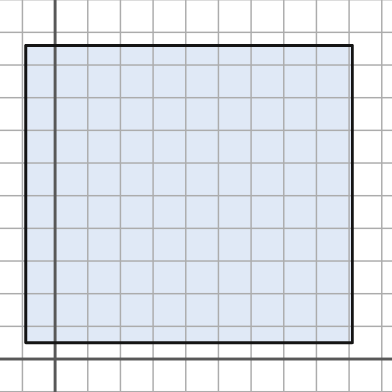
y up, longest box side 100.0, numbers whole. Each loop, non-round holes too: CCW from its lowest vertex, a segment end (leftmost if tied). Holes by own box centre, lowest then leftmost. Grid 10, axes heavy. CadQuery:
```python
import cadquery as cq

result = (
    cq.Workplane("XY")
    .moveTo(-9.0, 5.0)
    .lineTo(91.0, 5.0)
    .lineTo(91.0, 96.0)
    .lineTo(-9.0, 96.0)
    .close()
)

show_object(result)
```